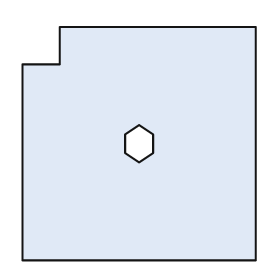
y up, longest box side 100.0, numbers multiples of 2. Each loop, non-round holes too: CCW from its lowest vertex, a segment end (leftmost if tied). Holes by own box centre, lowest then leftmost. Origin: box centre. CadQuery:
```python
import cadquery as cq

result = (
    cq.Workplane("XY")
    .moveTo(-50.0, -50.0)
    .lineTo(50.0, -50.0)
    .lineTo(50.0, 50.0)
    .lineTo(-34.0, 50.0)
    .lineTo(-34.0, 34.0)
    .lineTo(-50.0, 34.0)
    .close()
    .moveTo(0.0, -8.0)
    .lineTo(6.0, -4.0)
    .lineTo(6.0, 4.0)
    .lineTo(0.0, 8.0)
    .lineTo(-6.0, 4.0)
    .lineTo(-6.0, -4.0)
    .close()
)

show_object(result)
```